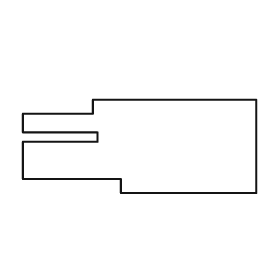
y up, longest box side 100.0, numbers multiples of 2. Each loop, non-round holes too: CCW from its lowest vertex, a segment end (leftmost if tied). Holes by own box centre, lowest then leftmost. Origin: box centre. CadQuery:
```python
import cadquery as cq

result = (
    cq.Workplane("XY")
    .moveTo(-8.0, -20.0)
    .lineTo(50.0, -20.0)
    .lineTo(50.0, 20.0)
    .lineTo(-20.0, 20.0)
    .lineTo(-20.0, 14.0)
    .lineTo(-50.0, 14.0)
    .lineTo(-50.0, 6.0)
    .lineTo(-18.0, 6.0)
    .lineTo(-18.0, 2.0)
    .lineTo(-50.0, 2.0)
    .lineTo(-50.0, -14.0)
    .lineTo(-8.0, -14.0)
    .close()
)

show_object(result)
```